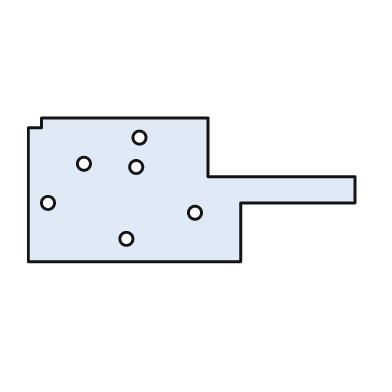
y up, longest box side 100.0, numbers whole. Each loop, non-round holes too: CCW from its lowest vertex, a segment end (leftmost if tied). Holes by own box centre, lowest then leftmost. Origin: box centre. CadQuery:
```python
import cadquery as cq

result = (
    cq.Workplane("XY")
    .moveTo(-50.0, -22.0)
    .lineTo(15.0, -22.0)
    .lineTo(15.0, -4.0)
    .lineTo(50.0, -4.0)
    .lineTo(50.0, 4.0)
    .lineTo(5.0, 4.0)
    .lineTo(5.0, 22.0)
    .lineTo(-46.0, 22.0)
    .lineTo(-46.0, 19.0)
    .lineTo(-50.0, 19.0)
    .close()
    .moveTo(-20.0, -15.0)
    .circle(2.0)
    .moveTo(1.0, -7.0)
    .circle(2.0)
    .moveTo(-44.0, -4.0)
    .circle(2.0)
    .moveTo(-17.0, 7.0)
    .circle(2.0)
    .moveTo(-33.0, 8.0)
    .circle(2.0)
    .moveTo(-16.0, 16.0)
    .circle(2.0)
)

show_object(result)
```